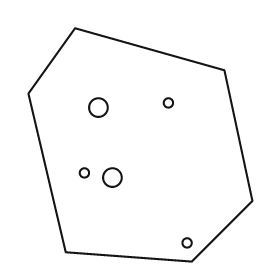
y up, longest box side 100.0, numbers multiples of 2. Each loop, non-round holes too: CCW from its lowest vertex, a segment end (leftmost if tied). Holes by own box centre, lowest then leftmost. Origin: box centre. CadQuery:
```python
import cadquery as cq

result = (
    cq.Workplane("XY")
    .moveTo(22.0, -50.0)
    .lineTo(48.0, -24.0)
    .lineTo(36.0, 32.0)
    .lineTo(-28.0, 50.0)
    .lineTo(-48.0, 22.0)
    .lineTo(-32.0, -46.0)
    .close()
    .moveTo(20.0, -42.0)
    .circle(2.0)
    .moveTo(-12.0, -14.0)
    .circle(4.0)
    .moveTo(-24.0, -12.0)
    .circle(2.0)
    .moveTo(-18.0, 16.0)
    .circle(4.0)
    .moveTo(12.0, 18.0)
    .circle(2.0)
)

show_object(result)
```